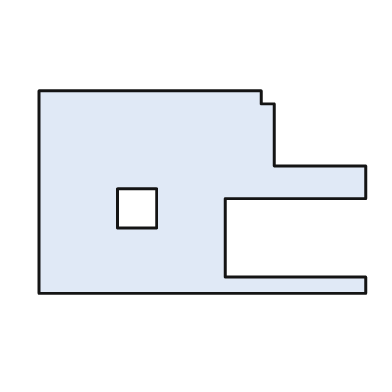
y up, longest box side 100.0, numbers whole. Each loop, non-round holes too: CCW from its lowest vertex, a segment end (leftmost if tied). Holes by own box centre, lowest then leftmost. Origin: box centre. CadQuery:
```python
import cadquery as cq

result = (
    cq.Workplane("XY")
    .moveTo(-50.0, -31.0)
    .lineTo(50.0, -31.0)
    .lineTo(50.0, -26.0)
    .lineTo(7.0, -26.0)
    .lineTo(7.0, -2.0)
    .lineTo(50.0, -2.0)
    .lineTo(50.0, 8.0)
    .lineTo(22.0, 8.0)
    .lineTo(22.0, 27.0)
    .lineTo(18.0, 27.0)
    .lineTo(18.0, 31.0)
    .lineTo(-50.0, 31.0)
    .close()
    .moveTo(-26.0, -11.0)
    .lineTo(-14.0, -11.0)
    .lineTo(-14.0, 1.0)
    .lineTo(-26.0, 1.0)
    .close()
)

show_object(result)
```